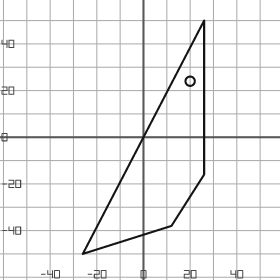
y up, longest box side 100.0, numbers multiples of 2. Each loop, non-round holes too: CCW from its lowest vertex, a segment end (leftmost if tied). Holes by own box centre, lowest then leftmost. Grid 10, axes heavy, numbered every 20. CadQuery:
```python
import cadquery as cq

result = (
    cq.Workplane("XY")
    .moveTo(-26.0, -50.0)
    .lineTo(12.0, -38.0)
    .lineTo(26.0, -16.0)
    .lineTo(26.0, 50.0)
    .close()
    .moveTo(20.0, 24.0)
    .circle(2.0)
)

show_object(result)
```